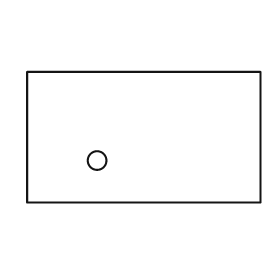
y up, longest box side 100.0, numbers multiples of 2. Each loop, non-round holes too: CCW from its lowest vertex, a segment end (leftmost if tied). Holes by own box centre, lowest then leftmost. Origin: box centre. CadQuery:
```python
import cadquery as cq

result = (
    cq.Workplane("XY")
    .moveTo(-50.0, -28.0)
    .lineTo(50.0, -28.0)
    .lineTo(50.0, 28.0)
    .lineTo(-50.0, 28.0)
    .close()
    .moveTo(-20.0, -10.0)
    .circle(4.0)
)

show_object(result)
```